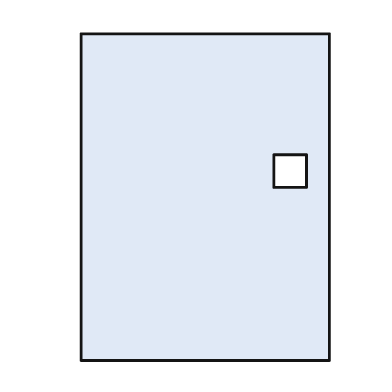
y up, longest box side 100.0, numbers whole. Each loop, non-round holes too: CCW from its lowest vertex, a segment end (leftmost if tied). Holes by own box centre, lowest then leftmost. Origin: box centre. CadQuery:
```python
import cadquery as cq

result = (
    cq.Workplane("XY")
    .moveTo(-38.0, -50.0)
    .lineTo(38.0, -50.0)
    .lineTo(38.0, 50.0)
    .lineTo(-38.0, 50.0)
    .close()
    .moveTo(21.0, 3.0)
    .lineTo(31.0, 3.0)
    .lineTo(31.0, 13.0)
    .lineTo(21.0, 13.0)
    .close()
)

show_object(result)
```